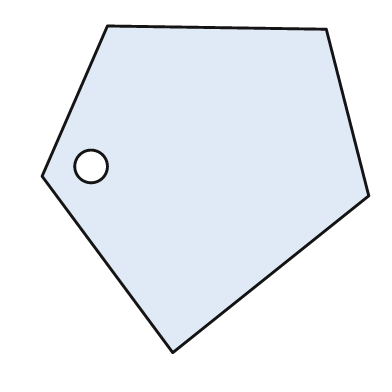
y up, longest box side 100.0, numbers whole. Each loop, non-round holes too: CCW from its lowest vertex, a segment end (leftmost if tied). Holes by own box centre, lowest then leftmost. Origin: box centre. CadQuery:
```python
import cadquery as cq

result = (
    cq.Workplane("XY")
    .moveTo(-10.0, -50.0)
    .lineTo(50.0, -2.0)
    .lineTo(37.0, 49.0)
    .lineTo(-30.0, 50.0)
    .lineTo(-50.0, 4.0)
    .close()
    .moveTo(-35.0, 7.0)
    .circle(5.0)
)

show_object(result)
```